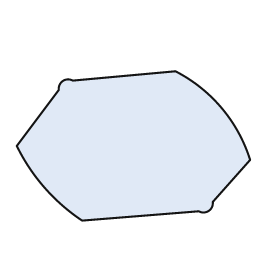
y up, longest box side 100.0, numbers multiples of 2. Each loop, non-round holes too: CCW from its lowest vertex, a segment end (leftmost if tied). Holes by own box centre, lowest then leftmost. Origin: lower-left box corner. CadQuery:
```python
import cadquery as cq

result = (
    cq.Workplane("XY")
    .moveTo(28.0, 0.0)
    .lineTo(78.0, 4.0)
    .threePointArc((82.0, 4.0), (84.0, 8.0))
    .lineTo(100.0, 26.0)
    .threePointArc((88.0, 48.0), (68.0, 64.0))
    .lineTo(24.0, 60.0)
    .threePointArc((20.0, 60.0), (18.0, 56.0))
    .lineTo(0.0, 32.0)
    .threePointArc((12.0, 14.0), (28.0, 0.0))
    .close()
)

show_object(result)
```